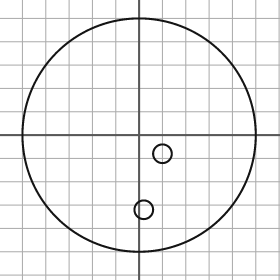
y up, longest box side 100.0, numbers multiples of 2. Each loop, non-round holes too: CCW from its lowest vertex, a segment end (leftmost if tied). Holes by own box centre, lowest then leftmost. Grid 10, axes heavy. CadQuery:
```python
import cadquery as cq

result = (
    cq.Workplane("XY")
    .moveTo(0.0, 0.0)
    .circle(50.0)
    .moveTo(2.0, -32.0)
    .circle(4.0)
    .moveTo(10.0, -8.0)
    .circle(4.0)
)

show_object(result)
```